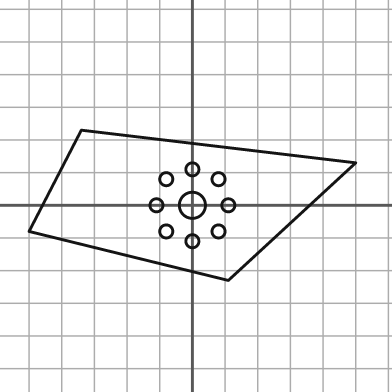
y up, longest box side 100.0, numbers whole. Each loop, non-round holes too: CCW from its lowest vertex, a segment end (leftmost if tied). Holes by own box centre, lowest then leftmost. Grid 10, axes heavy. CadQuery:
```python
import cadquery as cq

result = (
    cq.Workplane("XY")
    .moveTo(11.0, -23.0)
    .lineTo(50.0, 13.0)
    .lineTo(-34.0, 23.0)
    .lineTo(-50.0, -8.0)
    .close()
    .moveTo(0.0, -11.0)
    .circle(2.0)
    .moveTo(-8.0, -8.0)
    .circle(2.0)
    .moveTo(8.0, -8.0)
    .circle(2.0)
    .moveTo(-11.0, 0.0)
    .circle(2.0)
    .moveTo(0.0, 0.0)
    .circle(4.0)
    .moveTo(11.0, 0.0)
    .circle(2.0)
    .moveTo(-8.0, 8.0)
    .circle(2.0)
    .moveTo(8.0, 8.0)
    .circle(2.0)
    .moveTo(0.0, 11.0)
    .circle(2.0)
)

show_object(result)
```